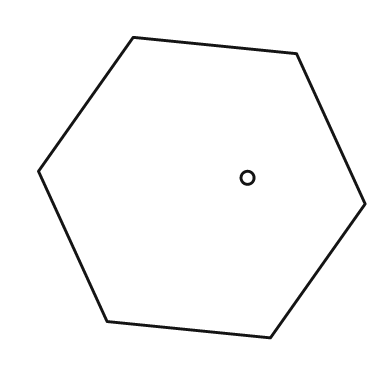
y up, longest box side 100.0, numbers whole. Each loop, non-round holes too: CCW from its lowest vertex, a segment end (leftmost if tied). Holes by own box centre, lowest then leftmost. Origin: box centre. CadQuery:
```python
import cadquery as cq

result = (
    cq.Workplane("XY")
    .moveTo(21.0, -46.0)
    .lineTo(50.0, -5.0)
    .lineTo(29.0, 41.0)
    .lineTo(-21.0, 46.0)
    .lineTo(-50.0, 5.0)
    .lineTo(-29.0, -41.0)
    .close()
    .moveTo(14.0, 3.0)
    .circle(2.0)
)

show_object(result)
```